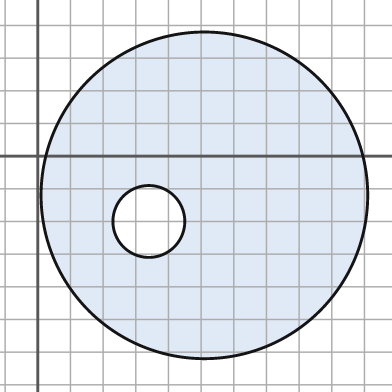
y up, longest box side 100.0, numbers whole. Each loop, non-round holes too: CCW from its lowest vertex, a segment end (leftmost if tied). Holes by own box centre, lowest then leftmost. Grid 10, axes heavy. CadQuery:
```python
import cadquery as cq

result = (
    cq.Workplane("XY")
    .moveTo(51.0, -12.0)
    .circle(50.0)
    .moveTo(34.0, -20.0)
    .circle(11.0)
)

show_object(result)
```